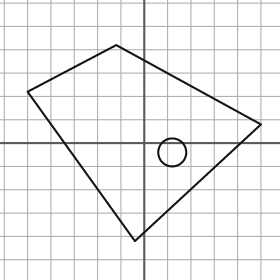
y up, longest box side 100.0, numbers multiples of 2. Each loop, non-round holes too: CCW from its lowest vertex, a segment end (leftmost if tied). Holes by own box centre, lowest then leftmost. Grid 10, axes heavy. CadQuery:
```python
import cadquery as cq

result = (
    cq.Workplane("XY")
    .moveTo(-4.0, -42.0)
    .lineTo(50.0, 8.0)
    .lineTo(-12.0, 42.0)
    .lineTo(-50.0, 22.0)
    .close()
    .moveTo(12.0, -4.0)
    .circle(6.0)
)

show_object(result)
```